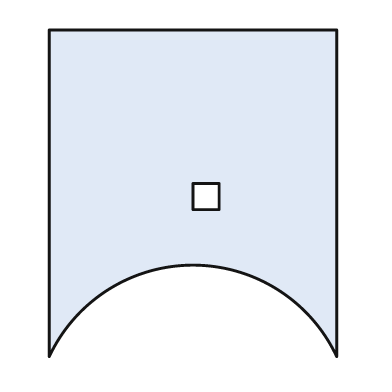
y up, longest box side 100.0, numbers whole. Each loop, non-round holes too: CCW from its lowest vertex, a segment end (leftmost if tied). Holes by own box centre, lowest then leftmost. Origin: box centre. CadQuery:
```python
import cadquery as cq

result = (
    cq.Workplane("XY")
    .moveTo(-44.0, -50.0)
    .threePointArc((0.0, -22.0), (44.0, -50.0))
    .lineTo(44.0, 50.0)
    .lineTo(-44.0, 50.0)
    .close()
    .moveTo(0.0, -5.0)
    .lineTo(8.0, -5.0)
    .lineTo(8.0, 3.0)
    .lineTo(0.0, 3.0)
    .close()
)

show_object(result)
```